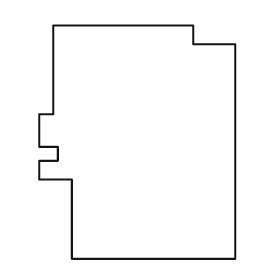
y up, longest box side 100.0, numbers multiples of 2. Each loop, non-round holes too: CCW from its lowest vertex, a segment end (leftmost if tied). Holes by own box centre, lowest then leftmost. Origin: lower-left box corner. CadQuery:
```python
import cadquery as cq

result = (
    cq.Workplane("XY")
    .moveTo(14.0, 0.0)
    .lineTo(84.0, 0.0)
    .lineTo(84.0, 92.0)
    .lineTo(66.0, 92.0)
    .lineTo(66.0, 100.0)
    .lineTo(6.0, 100.0)
    .lineTo(6.0, 62.0)
    .lineTo(0.0, 62.0)
    .lineTo(0.0, 48.0)
    .lineTo(8.0, 48.0)
    .lineTo(8.0, 42.0)
    .lineTo(0.0, 42.0)
    .lineTo(0.0, 34.0)
    .lineTo(14.0, 34.0)
    .close()
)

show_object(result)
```